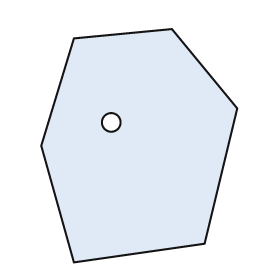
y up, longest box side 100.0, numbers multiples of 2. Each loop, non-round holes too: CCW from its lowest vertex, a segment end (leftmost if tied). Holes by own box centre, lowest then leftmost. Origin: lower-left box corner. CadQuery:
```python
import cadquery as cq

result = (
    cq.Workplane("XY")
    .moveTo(14.0, 0.0)
    .lineTo(70.0, 8.0)
    .lineTo(84.0, 66.0)
    .lineTo(56.0, 100.0)
    .lineTo(14.0, 96.0)
    .lineTo(0.0, 50.0)
    .close()
    .moveTo(30.0, 60.0)
    .circle(4.0)
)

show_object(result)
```